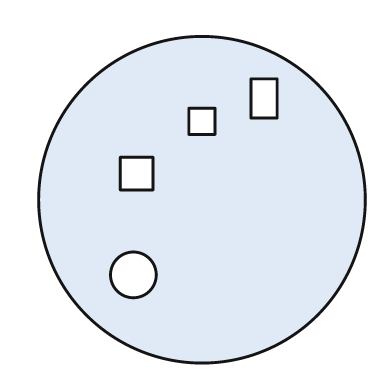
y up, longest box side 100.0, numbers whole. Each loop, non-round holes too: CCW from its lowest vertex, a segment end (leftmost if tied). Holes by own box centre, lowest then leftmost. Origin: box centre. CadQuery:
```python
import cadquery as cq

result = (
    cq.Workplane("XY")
    .moveTo(0.0, 0.0)
    .circle(50.0)
    .moveTo(-21.0, -23.0)
    .circle(7.0)
    .moveTo(-25.0, 3.0)
    .lineTo(-15.0, 3.0)
    .lineTo(-15.0, 13.0)
    .lineTo(-25.0, 13.0)
    .close()
    .moveTo(-4.0, 20.0)
    .lineTo(4.0, 20.0)
    .lineTo(4.0, 28.0)
    .lineTo(-4.0, 28.0)
    .close()
    .moveTo(15.0, 25.0)
    .lineTo(23.0, 25.0)
    .lineTo(23.0, 37.0)
    .lineTo(15.0, 37.0)
    .close()
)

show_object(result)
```